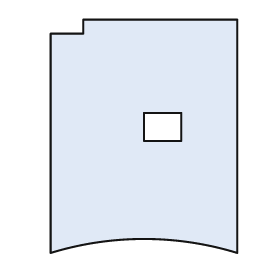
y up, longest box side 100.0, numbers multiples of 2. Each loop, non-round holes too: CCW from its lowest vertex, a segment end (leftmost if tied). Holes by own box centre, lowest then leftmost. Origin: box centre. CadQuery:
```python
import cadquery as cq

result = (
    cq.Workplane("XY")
    .moveTo(-40.0, -50.0)
    .threePointArc((0.0, -44.0), (40.0, -50.0))
    .lineTo(40.0, 50.0)
    .lineTo(-26.0, 50.0)
    .lineTo(-26.0, 44.0)
    .lineTo(-40.0, 44.0)
    .close()
    .moveTo(0.0, -2.0)
    .lineTo(16.0, -2.0)
    .lineTo(16.0, 10.0)
    .lineTo(0.0, 10.0)
    .close()
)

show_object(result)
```